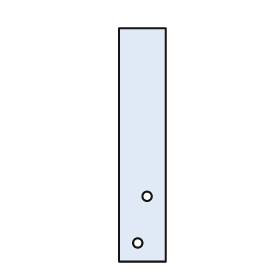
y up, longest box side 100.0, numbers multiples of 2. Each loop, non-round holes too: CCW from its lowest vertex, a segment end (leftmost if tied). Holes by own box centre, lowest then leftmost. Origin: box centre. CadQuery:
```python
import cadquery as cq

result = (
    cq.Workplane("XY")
    .moveTo(-10.0, -50.0)
    .lineTo(10.0, -50.0)
    .lineTo(10.0, 50.0)
    .lineTo(-10.0, 50.0)
    .close()
    .moveTo(-2.0, -42.0)
    .circle(2.0)
    .moveTo(2.0, -22.0)
    .circle(2.0)
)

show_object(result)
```